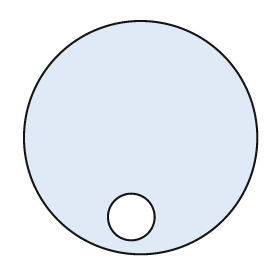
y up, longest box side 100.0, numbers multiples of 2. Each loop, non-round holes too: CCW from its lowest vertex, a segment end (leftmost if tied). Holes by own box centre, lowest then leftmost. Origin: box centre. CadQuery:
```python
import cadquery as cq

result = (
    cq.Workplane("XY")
    .moveTo(0.0, 0.0)
    .circle(50.0)
    .moveTo(-4.0, -34.0)
    .circle(10.0)
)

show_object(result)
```